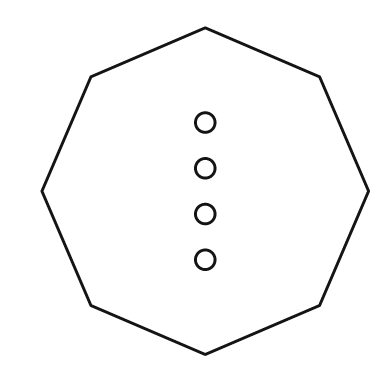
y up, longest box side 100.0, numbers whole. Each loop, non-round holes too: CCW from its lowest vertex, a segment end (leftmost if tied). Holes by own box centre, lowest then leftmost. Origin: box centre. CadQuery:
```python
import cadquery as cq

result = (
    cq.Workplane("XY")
    .moveTo(0.0, -50.0)
    .lineTo(35.0, -35.0)
    .lineTo(50.0, 0.0)
    .lineTo(35.0, 35.0)
    .lineTo(0.0, 50.0)
    .lineTo(-35.0, 35.0)
    .lineTo(-50.0, 0.0)
    .lineTo(-35.0, -35.0)
    .close()
    .moveTo(0.0, -21.0)
    .circle(3.0)
    .moveTo(0.0, -7.0)
    .circle(3.0)
    .moveTo(0.0, 7.0)
    .circle(3.0)
    .moveTo(0.0, 21.0)
    .circle(3.0)
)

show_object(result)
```